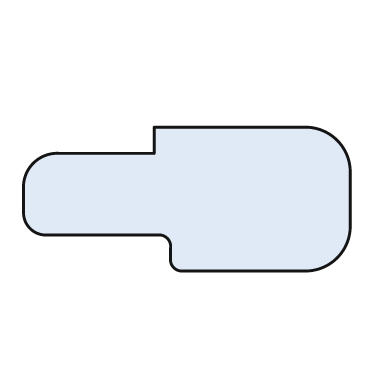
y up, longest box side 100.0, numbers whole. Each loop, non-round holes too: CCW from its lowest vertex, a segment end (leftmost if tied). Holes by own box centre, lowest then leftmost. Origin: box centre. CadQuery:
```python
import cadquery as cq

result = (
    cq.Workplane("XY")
    .moveTo(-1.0, -22.0)
    .lineTo(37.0, -22.0)
    .threePointArc((46.0, -18.0), (50.0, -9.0))
    .lineTo(50.0, 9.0)
    .threePointArc((46.0, 18.0), (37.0, 22.0))
    .lineTo(-10.0, 22.0)
    .lineTo(-10.0, 14.0)
    .lineTo(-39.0, 14.0)
    .threePointArc((-47.0, 11.0), (-50.0, 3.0))
    .lineTo(-50.0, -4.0)
    .threePointArc((-48.0, -9.0), (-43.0, -11.0))
    .lineTo(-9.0, -11.0)
    .threePointArc((-6.0, -12.0), (-5.0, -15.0))
    .lineTo(-5.0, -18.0)
    .threePointArc((-4.0, -21.0), (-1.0, -22.0))
    .close()
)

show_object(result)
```